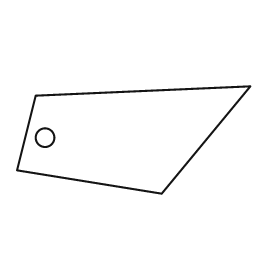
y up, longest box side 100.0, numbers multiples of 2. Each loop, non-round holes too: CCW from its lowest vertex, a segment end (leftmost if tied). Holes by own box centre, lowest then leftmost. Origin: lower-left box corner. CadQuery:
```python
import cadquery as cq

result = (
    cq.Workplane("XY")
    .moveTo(62.0, 0.0)
    .lineTo(100.0, 46.0)
    .lineTo(8.0, 42.0)
    .lineTo(0.0, 10.0)
    .close()
    .moveTo(12.0, 24.0)
    .circle(4.0)
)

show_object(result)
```